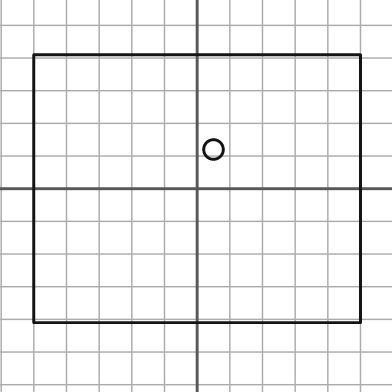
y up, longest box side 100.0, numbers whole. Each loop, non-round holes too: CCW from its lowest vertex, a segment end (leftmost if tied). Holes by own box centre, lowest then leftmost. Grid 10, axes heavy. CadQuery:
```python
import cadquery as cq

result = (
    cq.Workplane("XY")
    .moveTo(-50.0, -41.0)
    .lineTo(50.0, -41.0)
    .lineTo(50.0, 41.0)
    .lineTo(-50.0, 41.0)
    .close()
    .moveTo(5.0, 12.0)
    .circle(3.0)
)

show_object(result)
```